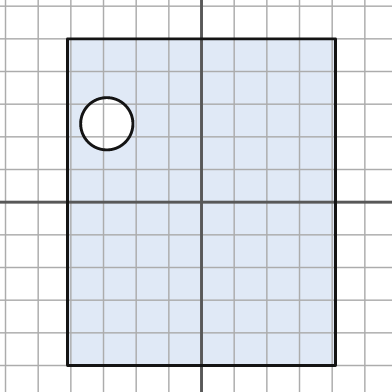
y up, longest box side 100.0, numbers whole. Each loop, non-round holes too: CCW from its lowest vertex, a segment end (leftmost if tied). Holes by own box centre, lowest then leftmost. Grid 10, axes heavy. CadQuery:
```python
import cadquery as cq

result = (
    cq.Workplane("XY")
    .moveTo(-41.0, -50.0)
    .lineTo(41.0, -50.0)
    .lineTo(41.0, 50.0)
    .lineTo(-41.0, 50.0)
    .close()
    .moveTo(-29.0, 24.0)
    .circle(8.0)
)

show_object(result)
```